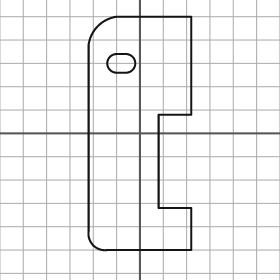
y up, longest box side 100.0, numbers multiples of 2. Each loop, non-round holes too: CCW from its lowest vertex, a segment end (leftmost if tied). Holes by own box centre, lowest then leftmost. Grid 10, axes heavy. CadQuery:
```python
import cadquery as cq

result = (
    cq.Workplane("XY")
    .moveTo(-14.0, -50.0)
    .lineTo(22.0, -50.0)
    .lineTo(22.0, -32.0)
    .lineTo(8.0, -32.0)
    .lineTo(8.0, 8.0)
    .lineTo(22.0, 8.0)
    .lineTo(22.0, 50.0)
    .lineTo(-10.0, 50.0)
    .threePointArc((-18.0, 46.0), (-22.0, 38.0))
    .lineTo(-22.0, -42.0)
    .threePointArc((-20.0, -48.0), (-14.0, -50.0))
    .close()
    .moveTo(-10.0, 26.0)
    .lineTo(-6.0, 26.0)
    .threePointArc((-2.0, 30.0), (-6.0, 34.0))
    .lineTo(-10.0, 34.0)
    .threePointArc((-14.0, 30.0), (-10.0, 26.0))
    .close()
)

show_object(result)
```